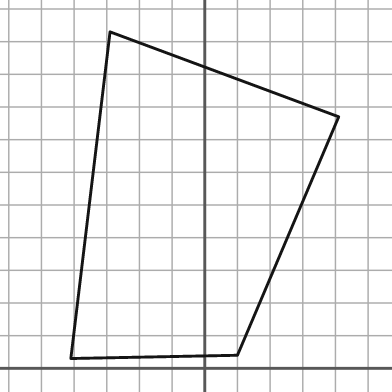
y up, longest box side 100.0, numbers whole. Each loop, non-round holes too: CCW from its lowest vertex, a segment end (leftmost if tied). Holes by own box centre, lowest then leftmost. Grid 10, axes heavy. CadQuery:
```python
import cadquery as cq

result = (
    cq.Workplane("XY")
    .moveTo(-41.0, 3.0)
    .lineTo(10.0, 4.0)
    .lineTo(41.0, 77.0)
    .lineTo(-29.0, 103.0)
    .close()
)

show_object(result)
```